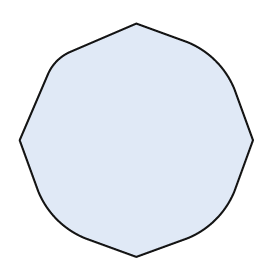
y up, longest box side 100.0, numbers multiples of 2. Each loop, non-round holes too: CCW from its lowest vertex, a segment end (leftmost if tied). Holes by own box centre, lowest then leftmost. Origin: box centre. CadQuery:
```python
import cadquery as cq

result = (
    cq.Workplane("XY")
    .moveTo(0.0, -50.0)
    .lineTo(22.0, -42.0)
    .threePointArc((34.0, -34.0), (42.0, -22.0))
    .lineTo(50.0, 0.0)
    .lineTo(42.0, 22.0)
    .threePointArc((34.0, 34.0), (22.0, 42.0))
    .lineTo(0.0, 50.0)
    .lineTo(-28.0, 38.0)
    .threePointArc((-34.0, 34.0), (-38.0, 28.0))
    .lineTo(-50.0, 0.0)
    .lineTo(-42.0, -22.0)
    .threePointArc((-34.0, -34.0), (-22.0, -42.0))
    .close()
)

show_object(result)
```